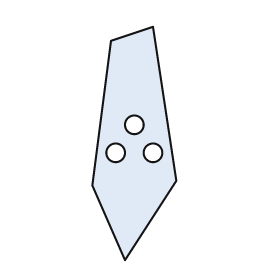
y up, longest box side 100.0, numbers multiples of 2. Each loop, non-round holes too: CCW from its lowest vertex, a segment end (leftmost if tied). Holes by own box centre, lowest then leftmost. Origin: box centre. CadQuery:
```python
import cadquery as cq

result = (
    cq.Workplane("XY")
    .moveTo(-4.0, -50.0)
    .lineTo(18.0, -16.0)
    .lineTo(8.0, 50.0)
    .lineTo(-10.0, 44.0)
    .lineTo(-18.0, -18.0)
    .close()
    .moveTo(-8.0, -4.0)
    .circle(4.0)
    .moveTo(8.0, -4.0)
    .circle(4.0)
    .moveTo(0.0, 8.0)
    .circle(4.0)
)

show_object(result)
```